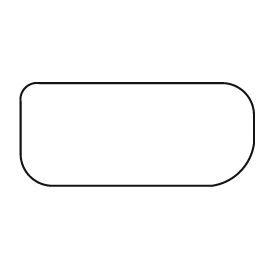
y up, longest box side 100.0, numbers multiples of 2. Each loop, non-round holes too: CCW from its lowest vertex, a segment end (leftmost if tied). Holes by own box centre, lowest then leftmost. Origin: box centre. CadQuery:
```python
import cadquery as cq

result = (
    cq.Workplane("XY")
    .moveTo(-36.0, -22.0)
    .lineTo(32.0, -22.0)
    .threePointArc((44.0, -16.0), (50.0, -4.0))
    .lineTo(50.0, 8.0)
    .threePointArc((46.0, 18.0), (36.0, 22.0))
    .lineTo(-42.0, 22.0)
    .threePointArc((-48.0, 20.0), (-50.0, 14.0))
    .lineTo(-50.0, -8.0)
    .threePointArc((-46.0, -18.0), (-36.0, -22.0))
    .close()
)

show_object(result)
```